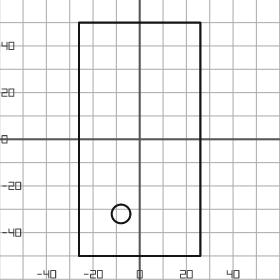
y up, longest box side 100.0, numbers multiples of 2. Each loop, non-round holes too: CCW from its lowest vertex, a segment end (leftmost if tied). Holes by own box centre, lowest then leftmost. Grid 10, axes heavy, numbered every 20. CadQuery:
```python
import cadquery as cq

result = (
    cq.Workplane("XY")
    .moveTo(-26.0, -50.0)
    .lineTo(26.0, -50.0)
    .lineTo(26.0, 50.0)
    .lineTo(-26.0, 50.0)
    .close()
    .moveTo(-8.0, -32.0)
    .circle(4.0)
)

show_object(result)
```